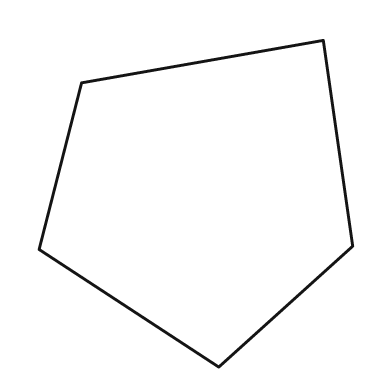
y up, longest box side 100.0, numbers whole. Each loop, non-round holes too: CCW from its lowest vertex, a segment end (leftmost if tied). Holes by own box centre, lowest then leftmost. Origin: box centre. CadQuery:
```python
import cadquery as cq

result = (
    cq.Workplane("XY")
    .moveTo(7.0, -50.0)
    .lineTo(48.0, -13.0)
    .lineTo(39.0, 50.0)
    .lineTo(-35.0, 37.0)
    .lineTo(-48.0, -14.0)
    .close()
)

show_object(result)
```